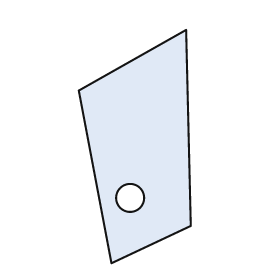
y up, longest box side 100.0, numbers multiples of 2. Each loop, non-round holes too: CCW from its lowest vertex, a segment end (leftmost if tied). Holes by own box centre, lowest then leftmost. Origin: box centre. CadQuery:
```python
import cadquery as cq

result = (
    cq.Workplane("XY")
    .moveTo(-10.0, -50.0)
    .lineTo(24.0, -34.0)
    .lineTo(22.0, 50.0)
    .lineTo(-24.0, 24.0)
    .close()
    .moveTo(-2.0, -22.0)
    .circle(6.0)
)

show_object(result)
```